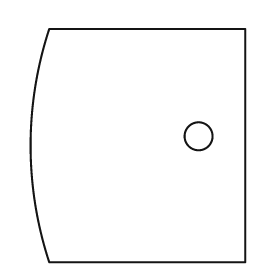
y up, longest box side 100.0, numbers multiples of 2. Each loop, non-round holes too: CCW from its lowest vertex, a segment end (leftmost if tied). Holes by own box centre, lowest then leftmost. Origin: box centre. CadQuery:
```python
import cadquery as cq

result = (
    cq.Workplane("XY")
    .moveTo(-38.0, -50.0)
    .lineTo(46.0, -50.0)
    .lineTo(46.0, 50.0)
    .lineTo(-38.0, 50.0)
    .threePointArc((-46.0, 0.0), (-38.0, -50.0))
    .close()
    .moveTo(26.0, 4.0)
    .circle(6.0)
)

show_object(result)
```